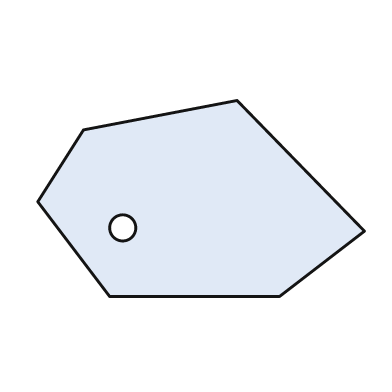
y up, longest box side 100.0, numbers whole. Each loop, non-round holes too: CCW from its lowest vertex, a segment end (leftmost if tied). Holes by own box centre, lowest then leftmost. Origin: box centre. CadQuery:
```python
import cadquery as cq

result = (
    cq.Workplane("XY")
    .moveTo(-28.0, -30.0)
    .lineTo(24.0, -30.0)
    .lineTo(50.0, -10.0)
    .lineTo(11.0, 30.0)
    .lineTo(-36.0, 21.0)
    .lineTo(-50.0, -1.0)
    .close()
    .moveTo(-24.0, -9.0)
    .circle(4.0)
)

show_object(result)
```